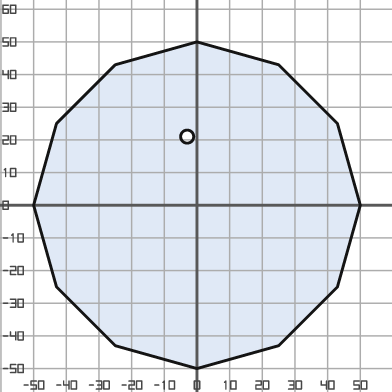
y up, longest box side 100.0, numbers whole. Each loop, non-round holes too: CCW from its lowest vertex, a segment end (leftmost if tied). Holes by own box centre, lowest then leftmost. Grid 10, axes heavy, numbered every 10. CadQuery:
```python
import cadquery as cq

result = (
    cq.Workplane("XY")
    .moveTo(0.0, -50.0)
    .lineTo(25.0, -43.0)
    .lineTo(43.0, -25.0)
    .lineTo(50.0, 0.0)
    .lineTo(43.0, 25.0)
    .lineTo(25.0, 43.0)
    .lineTo(0.0, 50.0)
    .lineTo(-25.0, 43.0)
    .lineTo(-43.0, 25.0)
    .lineTo(-50.0, 0.0)
    .lineTo(-43.0, -25.0)
    .lineTo(-25.0, -43.0)
    .close()
    .moveTo(-3.0, 21.0)
    .circle(2.0)
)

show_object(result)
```